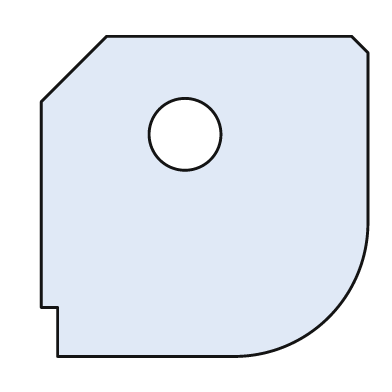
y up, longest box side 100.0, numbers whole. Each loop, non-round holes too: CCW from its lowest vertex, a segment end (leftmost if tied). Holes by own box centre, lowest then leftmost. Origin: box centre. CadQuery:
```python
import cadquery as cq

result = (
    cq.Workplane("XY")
    .moveTo(-45.0, -49.0)
    .lineTo(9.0, -49.0)
    .threePointArc((38.0, -37.0), (50.0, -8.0))
    .lineTo(50.0, 44.0)
    .lineTo(45.0, 49.0)
    .lineTo(-30.0, 49.0)
    .lineTo(-50.0, 29.0)
    .lineTo(-50.0, -34.0)
    .lineTo(-45.0, -34.0)
    .close()
    .moveTo(-6.0, 19.0)
    .circle(11.0)
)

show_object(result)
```